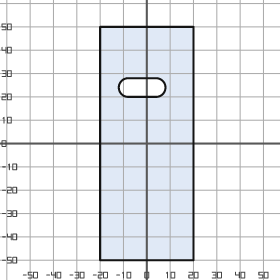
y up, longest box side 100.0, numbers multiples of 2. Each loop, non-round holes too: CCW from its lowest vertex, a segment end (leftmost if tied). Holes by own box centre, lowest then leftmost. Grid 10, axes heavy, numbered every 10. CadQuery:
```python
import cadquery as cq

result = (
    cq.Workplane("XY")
    .moveTo(-20.0, -50.0)
    .lineTo(20.0, -50.0)
    .lineTo(20.0, 50.0)
    .lineTo(-20.0, 50.0)
    .close()
    .moveTo(-8.0, 20.0)
    .lineTo(4.0, 20.0)
    .threePointArc((8.0, 24.0), (4.0, 28.0))
    .lineTo(-8.0, 28.0)
    .threePointArc((-12.0, 24.0), (-8.0, 20.0))
    .close()
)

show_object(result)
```